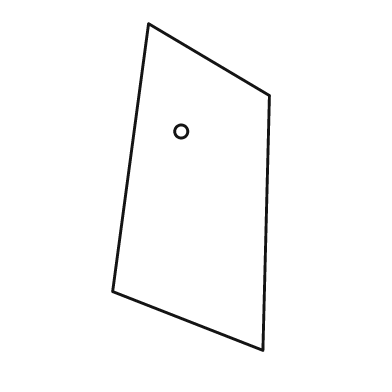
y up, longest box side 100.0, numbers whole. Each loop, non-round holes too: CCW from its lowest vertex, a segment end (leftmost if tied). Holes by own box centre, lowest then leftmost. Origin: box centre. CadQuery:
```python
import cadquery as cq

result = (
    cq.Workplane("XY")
    .moveTo(22.0, -50.0)
    .lineTo(24.0, 28.0)
    .lineTo(-13.0, 50.0)
    .lineTo(-24.0, -32.0)
    .close()
    .moveTo(-3.0, 17.0)
    .circle(2.0)
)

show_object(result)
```